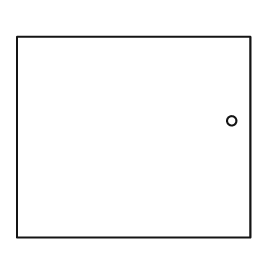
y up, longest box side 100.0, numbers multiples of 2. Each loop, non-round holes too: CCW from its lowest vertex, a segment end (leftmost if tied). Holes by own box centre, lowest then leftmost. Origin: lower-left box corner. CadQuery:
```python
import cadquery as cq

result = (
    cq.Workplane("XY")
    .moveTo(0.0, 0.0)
    .lineTo(100.0, 0.0)
    .lineTo(100.0, 86.0)
    .lineTo(0.0, 86.0)
    .close()
    .moveTo(92.0, 50.0)
    .circle(2.0)
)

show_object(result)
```